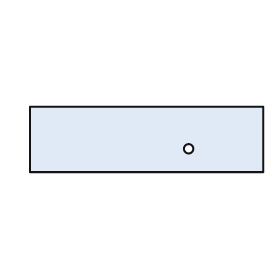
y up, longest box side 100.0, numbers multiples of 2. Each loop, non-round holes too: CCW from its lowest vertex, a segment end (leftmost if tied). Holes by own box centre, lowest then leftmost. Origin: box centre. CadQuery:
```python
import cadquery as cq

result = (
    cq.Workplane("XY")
    .moveTo(-50.0, -14.0)
    .lineTo(50.0, -14.0)
    .lineTo(50.0, 14.0)
    .lineTo(-50.0, 14.0)
    .close()
    .moveTo(18.0, -4.0)
    .circle(2.0)
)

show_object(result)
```